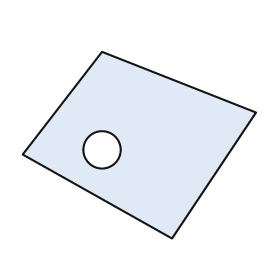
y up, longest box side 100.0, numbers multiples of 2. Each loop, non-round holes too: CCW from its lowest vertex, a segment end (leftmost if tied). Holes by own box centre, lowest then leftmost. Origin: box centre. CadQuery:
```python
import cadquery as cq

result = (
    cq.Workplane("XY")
    .moveTo(14.0, -40.0)
    .lineTo(50.0, 14.0)
    .lineTo(-16.0, 40.0)
    .lineTo(-50.0, -4.0)
    .close()
    .moveTo(-16.0, -2.0)
    .circle(8.0)
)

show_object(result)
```